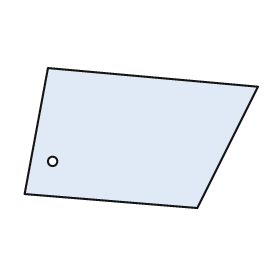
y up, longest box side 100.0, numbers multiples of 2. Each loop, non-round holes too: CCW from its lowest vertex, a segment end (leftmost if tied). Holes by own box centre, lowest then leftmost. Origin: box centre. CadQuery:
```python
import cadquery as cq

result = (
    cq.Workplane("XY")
    .moveTo(24.0, -30.0)
    .lineTo(50.0, 22.0)
    .lineTo(-40.0, 30.0)
    .lineTo(-50.0, -24.0)
    .close()
    .moveTo(-38.0, -10.0)
    .circle(2.0)
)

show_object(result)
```